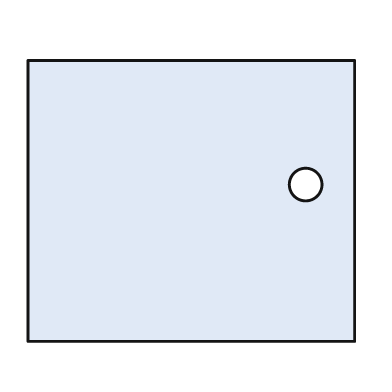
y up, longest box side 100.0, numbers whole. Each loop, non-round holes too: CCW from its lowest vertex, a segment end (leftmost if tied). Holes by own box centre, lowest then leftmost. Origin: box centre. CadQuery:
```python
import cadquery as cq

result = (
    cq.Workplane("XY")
    .moveTo(-50.0, -43.0)
    .lineTo(50.0, -43.0)
    .lineTo(50.0, 43.0)
    .lineTo(-50.0, 43.0)
    .close()
    .moveTo(35.0, 5.0)
    .circle(5.0)
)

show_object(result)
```